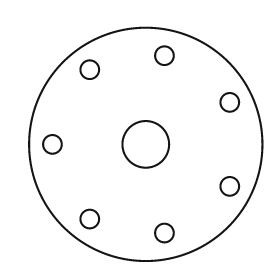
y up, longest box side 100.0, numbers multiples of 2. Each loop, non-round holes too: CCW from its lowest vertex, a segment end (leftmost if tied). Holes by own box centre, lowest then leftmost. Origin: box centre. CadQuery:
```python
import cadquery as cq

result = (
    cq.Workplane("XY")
    .moveTo(0.0, 0.0)
    .circle(50.0)
    .moveTo(8.0, -38.0)
    .circle(4.0)
    .moveTo(-24.0, -32.0)
    .circle(4.0)
    .moveTo(36.0, -18.0)
    .circle(4.0)
    .moveTo(-40.0, 0.0)
    .circle(4.0)
    .moveTo(0.0, 0.0)
    .circle(10.0)
    .moveTo(36.0, 18.0)
    .circle(4.0)
    .moveTo(-24.0, 32.0)
    .circle(4.0)
    .moveTo(8.0, 38.0)
    .circle(4.0)
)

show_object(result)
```